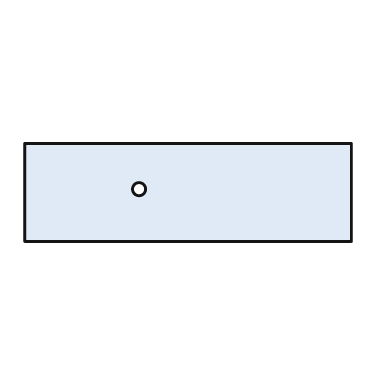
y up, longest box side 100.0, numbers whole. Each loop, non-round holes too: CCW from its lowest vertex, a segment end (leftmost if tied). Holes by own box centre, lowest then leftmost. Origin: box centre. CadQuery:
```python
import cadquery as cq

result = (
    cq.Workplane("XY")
    .moveTo(-50.0, -15.0)
    .lineTo(50.0, -15.0)
    .lineTo(50.0, 15.0)
    .lineTo(-50.0, 15.0)
    .close()
    .moveTo(-15.0, 1.0)
    .circle(2.0)
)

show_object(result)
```